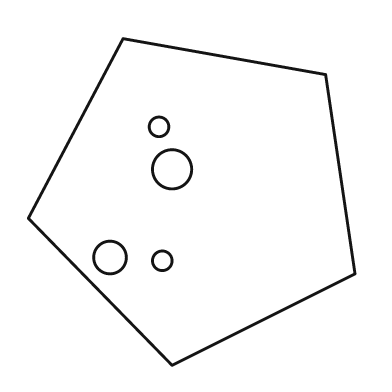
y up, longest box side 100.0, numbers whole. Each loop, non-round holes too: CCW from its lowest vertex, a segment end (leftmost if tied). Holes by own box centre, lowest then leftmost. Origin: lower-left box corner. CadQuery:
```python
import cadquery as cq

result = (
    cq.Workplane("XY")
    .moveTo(44.0, 0.0)
    .lineTo(100.0, 28.0)
    .lineTo(91.0, 89.0)
    .lineTo(29.0, 100.0)
    .lineTo(0.0, 45.0)
    .close()
    .moveTo(41.0, 32.0)
    .circle(3.0)
    .moveTo(25.0, 33.0)
    .circle(5.0)
    .moveTo(44.0, 60.0)
    .circle(6.0)
    .moveTo(40.0, 73.0)
    .circle(3.0)
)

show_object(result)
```